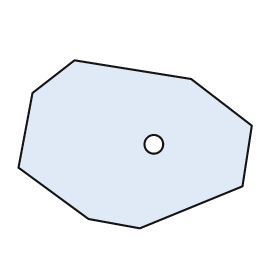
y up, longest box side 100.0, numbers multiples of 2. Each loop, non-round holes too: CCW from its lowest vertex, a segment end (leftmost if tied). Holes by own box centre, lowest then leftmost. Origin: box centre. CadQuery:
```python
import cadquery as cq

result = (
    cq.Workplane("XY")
    .moveTo(2.0, -36.0)
    .lineTo(46.0, -18.0)
    .lineTo(50.0, 8.0)
    .lineTo(24.0, 28.0)
    .lineTo(-26.0, 36.0)
    .lineTo(-44.0, 22.0)
    .lineTo(-50.0, -10.0)
    .lineTo(-20.0, -32.0)
    .close()
    .moveTo(8.0, 0.0)
    .circle(4.0)
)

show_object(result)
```